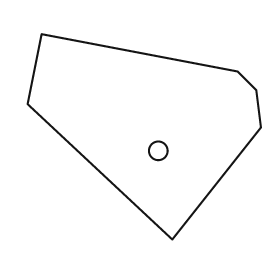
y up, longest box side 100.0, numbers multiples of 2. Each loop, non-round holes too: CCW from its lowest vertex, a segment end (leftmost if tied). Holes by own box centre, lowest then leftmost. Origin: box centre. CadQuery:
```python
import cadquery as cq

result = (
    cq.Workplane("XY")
    .moveTo(12.0, -44.0)
    .lineTo(50.0, 4.0)
    .lineTo(48.0, 20.0)
    .lineTo(40.0, 28.0)
    .lineTo(-44.0, 44.0)
    .lineTo(-50.0, 14.0)
    .close()
    .moveTo(6.0, -6.0)
    .circle(4.0)
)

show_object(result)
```